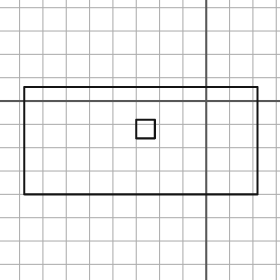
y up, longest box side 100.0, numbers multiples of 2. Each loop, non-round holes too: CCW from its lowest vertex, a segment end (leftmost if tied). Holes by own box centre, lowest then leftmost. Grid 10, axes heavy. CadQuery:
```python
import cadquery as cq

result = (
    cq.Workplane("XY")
    .moveTo(-78.0, -40.0)
    .lineTo(22.0, -40.0)
    .lineTo(22.0, 6.0)
    .lineTo(-78.0, 6.0)
    .close()
    .moveTo(-30.0, -16.0)
    .lineTo(-22.0, -16.0)
    .lineTo(-22.0, -8.0)
    .lineTo(-30.0, -8.0)
    .close()
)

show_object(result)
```